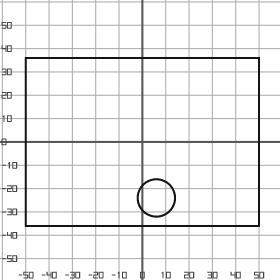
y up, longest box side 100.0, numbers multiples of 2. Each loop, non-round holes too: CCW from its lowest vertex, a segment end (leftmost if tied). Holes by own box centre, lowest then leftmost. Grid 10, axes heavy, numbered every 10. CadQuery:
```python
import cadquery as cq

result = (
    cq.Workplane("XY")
    .moveTo(-50.0, -36.0)
    .lineTo(50.0, -36.0)
    .lineTo(50.0, 36.0)
    .lineTo(-50.0, 36.0)
    .close()
    .moveTo(6.0, -24.0)
    .circle(8.0)
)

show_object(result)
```